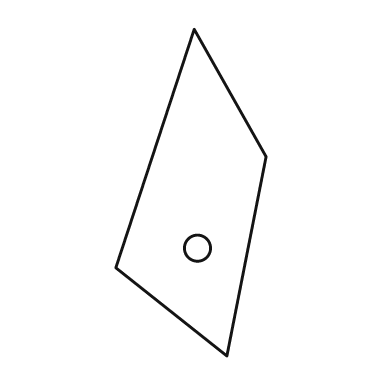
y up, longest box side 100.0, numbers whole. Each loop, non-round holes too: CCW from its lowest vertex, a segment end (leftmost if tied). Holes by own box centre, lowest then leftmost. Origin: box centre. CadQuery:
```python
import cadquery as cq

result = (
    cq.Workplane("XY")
    .moveTo(11.0, -50.0)
    .lineTo(23.0, 11.0)
    .lineTo(1.0, 50.0)
    .lineTo(-23.0, -23.0)
    .close()
    .moveTo(2.0, -17.0)
    .circle(4.0)
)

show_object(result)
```